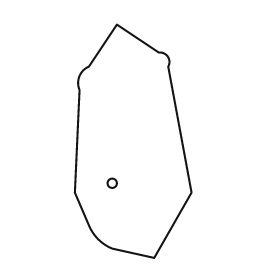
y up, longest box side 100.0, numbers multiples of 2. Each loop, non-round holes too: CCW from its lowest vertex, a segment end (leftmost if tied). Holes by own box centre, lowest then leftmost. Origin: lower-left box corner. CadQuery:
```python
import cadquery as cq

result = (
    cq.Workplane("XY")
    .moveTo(34.0, 0.0)
    .lineTo(50.0, 28.0)
    .lineTo(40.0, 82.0)
    .threePointArc((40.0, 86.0), (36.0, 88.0))
    .lineTo(18.0, 100.0)
    .lineTo(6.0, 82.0)
    .threePointArc((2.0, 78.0), (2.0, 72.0))
    .lineTo(0.0, 28.0)
    .lineTo(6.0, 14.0)
    .threePointArc((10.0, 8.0), (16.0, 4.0))
    .close()
    .moveTo(16.0, 32.0)
    .circle(2.0)
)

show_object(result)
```